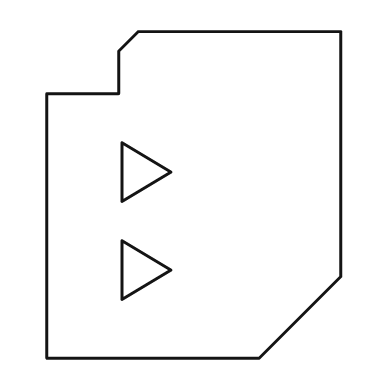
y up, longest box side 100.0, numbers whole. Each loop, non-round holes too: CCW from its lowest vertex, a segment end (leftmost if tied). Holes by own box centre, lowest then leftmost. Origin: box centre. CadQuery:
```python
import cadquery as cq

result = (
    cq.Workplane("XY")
    .moveTo(-45.0, -50.0)
    .lineTo(20.0, -50.0)
    .lineTo(45.0, -25.0)
    .lineTo(45.0, 50.0)
    .lineTo(-17.0, 50.0)
    .lineTo(-23.0, 44.0)
    .lineTo(-23.0, 31.0)
    .lineTo(-45.0, 31.0)
    .close()
    .moveTo(-22.0, -32.0)
    .lineTo(-7.0, -23.0)
    .lineTo(-22.0, -14.0)
    .close()
    .moveTo(-22.0, -2.0)
    .lineTo(-7.0, 7.0)
    .lineTo(-22.0, 16.0)
    .close()
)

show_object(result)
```